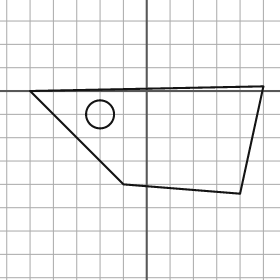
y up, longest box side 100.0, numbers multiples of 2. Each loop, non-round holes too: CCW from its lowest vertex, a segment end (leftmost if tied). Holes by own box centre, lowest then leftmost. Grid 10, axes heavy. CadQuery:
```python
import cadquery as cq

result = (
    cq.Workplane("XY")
    .moveTo(40.0, -44.0)
    .lineTo(50.0, 2.0)
    .lineTo(-50.0, 0.0)
    .lineTo(-10.0, -40.0)
    .close()
    .moveTo(-20.0, -10.0)
    .circle(6.0)
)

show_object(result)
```